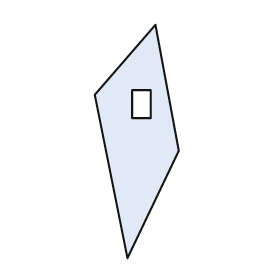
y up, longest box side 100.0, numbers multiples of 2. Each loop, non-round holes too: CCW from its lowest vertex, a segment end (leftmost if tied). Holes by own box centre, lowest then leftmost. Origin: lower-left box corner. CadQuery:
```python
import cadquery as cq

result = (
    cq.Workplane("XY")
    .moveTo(14.0, 0.0)
    .lineTo(36.0, 46.0)
    .lineTo(26.0, 100.0)
    .lineTo(0.0, 70.0)
    .close()
    .moveTo(16.0, 60.0)
    .lineTo(24.0, 60.0)
    .lineTo(24.0, 72.0)
    .lineTo(16.0, 72.0)
    .close()
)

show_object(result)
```